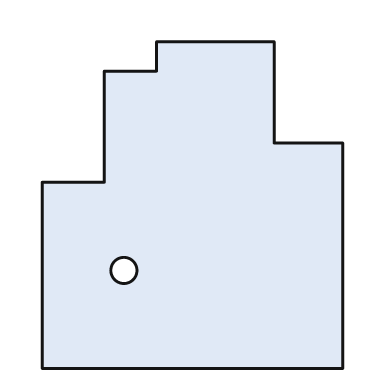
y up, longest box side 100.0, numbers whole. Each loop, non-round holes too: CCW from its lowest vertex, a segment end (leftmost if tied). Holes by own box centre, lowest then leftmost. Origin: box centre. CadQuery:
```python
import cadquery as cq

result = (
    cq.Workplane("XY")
    .moveTo(-46.0, -50.0)
    .lineTo(46.0, -50.0)
    .lineTo(46.0, 19.0)
    .lineTo(25.0, 19.0)
    .lineTo(25.0, 50.0)
    .lineTo(-11.0, 50.0)
    .lineTo(-11.0, 41.0)
    .lineTo(-27.0, 41.0)
    .lineTo(-27.0, 7.0)
    .lineTo(-46.0, 7.0)
    .close()
    .moveTo(-21.0, -20.0)
    .circle(4.0)
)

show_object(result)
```